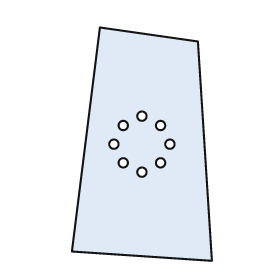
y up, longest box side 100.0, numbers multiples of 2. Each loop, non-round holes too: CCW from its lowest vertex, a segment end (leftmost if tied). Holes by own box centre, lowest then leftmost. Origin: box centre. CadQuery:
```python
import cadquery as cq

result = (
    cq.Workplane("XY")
    .moveTo(30.0, -50.0)
    .lineTo(24.0, 44.0)
    .lineTo(-18.0, 50.0)
    .lineTo(-30.0, -46.0)
    .close()
    .moveTo(0.0, -12.0)
    .circle(2.0)
    .moveTo(-8.0, -8.0)
    .circle(2.0)
    .moveTo(8.0, -8.0)
    .circle(2.0)
    .moveTo(-12.0, 0.0)
    .circle(2.0)
    .moveTo(12.0, 0.0)
    .circle(2.0)
    .moveTo(-8.0, 8.0)
    .circle(2.0)
    .moveTo(8.0, 8.0)
    .circle(2.0)
    .moveTo(0.0, 12.0)
    .circle(2.0)
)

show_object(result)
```